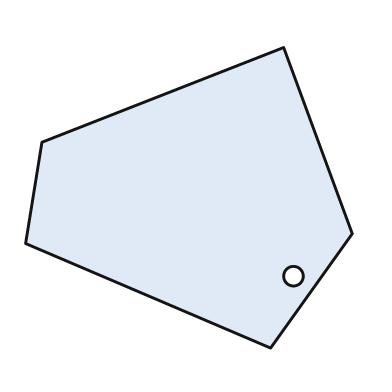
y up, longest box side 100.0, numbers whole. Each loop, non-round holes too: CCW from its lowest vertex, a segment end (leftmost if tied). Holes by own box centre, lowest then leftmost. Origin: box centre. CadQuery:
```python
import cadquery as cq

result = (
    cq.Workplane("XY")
    .moveTo(25.0, -46.0)
    .lineTo(50.0, -11.0)
    .lineTo(29.0, 46.0)
    .lineTo(-45.0, 17.0)
    .lineTo(-50.0, -14.0)
    .close()
    .moveTo(32.0, -24.0)
    .circle(3.0)
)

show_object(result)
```